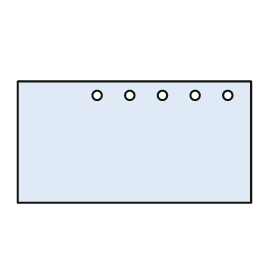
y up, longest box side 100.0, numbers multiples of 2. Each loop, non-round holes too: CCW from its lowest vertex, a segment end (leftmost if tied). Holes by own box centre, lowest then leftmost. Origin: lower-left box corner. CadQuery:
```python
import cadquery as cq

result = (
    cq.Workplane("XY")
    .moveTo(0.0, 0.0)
    .lineTo(100.0, 0.0)
    .lineTo(100.0, 52.0)
    .lineTo(0.0, 52.0)
    .close()
    .moveTo(34.0, 46.0)
    .circle(2.0)
    .moveTo(48.0, 46.0)
    .circle(2.0)
    .moveTo(62.0, 46.0)
    .circle(2.0)
    .moveTo(76.0, 46.0)
    .circle(2.0)
    .moveTo(90.0, 46.0)
    .circle(2.0)
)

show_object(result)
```